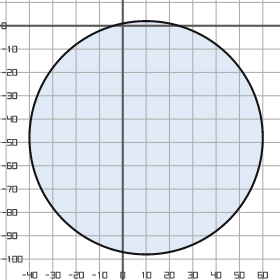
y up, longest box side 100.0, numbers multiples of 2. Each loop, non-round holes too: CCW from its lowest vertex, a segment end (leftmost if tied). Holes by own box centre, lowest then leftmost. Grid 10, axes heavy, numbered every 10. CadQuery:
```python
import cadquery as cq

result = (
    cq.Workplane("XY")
    .moveTo(10.0, -48.0)
    .circle(50.0)
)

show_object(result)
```